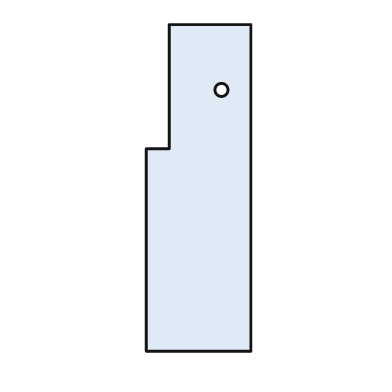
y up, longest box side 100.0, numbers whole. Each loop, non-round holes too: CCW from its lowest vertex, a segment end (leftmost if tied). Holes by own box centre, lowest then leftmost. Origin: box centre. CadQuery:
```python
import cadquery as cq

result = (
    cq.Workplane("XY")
    .moveTo(-16.0, -50.0)
    .lineTo(16.0, -50.0)
    .lineTo(16.0, 50.0)
    .lineTo(-9.0, 50.0)
    .lineTo(-9.0, 12.0)
    .lineTo(-16.0, 12.0)
    .close()
    .moveTo(7.0, 30.0)
    .circle(2.0)
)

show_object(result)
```